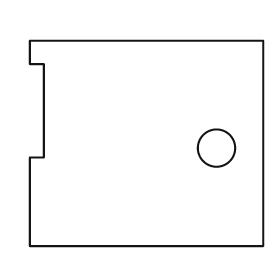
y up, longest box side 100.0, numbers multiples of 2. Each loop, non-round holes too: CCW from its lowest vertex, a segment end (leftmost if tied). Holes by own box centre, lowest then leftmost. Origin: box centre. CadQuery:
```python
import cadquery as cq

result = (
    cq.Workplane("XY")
    .moveTo(-50.0, -44.0)
    .lineTo(50.0, -44.0)
    .lineTo(50.0, 44.0)
    .lineTo(-50.0, 44.0)
    .lineTo(-50.0, 34.0)
    .lineTo(-44.0, 34.0)
    .lineTo(-44.0, -6.0)
    .lineTo(-50.0, -6.0)
    .close()
    .moveTo(30.0, -2.0)
    .circle(8.0)
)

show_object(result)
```